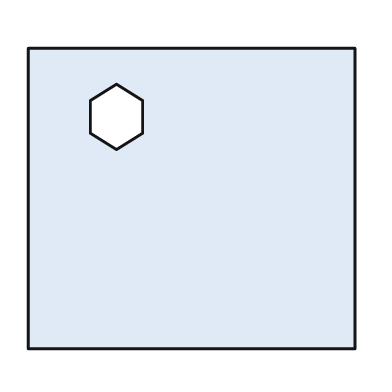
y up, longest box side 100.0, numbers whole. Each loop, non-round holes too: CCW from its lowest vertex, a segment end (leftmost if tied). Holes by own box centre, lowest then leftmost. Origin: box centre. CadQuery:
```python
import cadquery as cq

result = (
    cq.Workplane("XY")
    .moveTo(-50.0, -46.0)
    .lineTo(50.0, -46.0)
    .lineTo(50.0, 46.0)
    .lineTo(-50.0, 46.0)
    .close()
    .moveTo(-23.0, 15.0)
    .lineTo(-15.0, 20.0)
    .lineTo(-15.0, 30.0)
    .lineTo(-23.0, 35.0)
    .lineTo(-31.0, 30.0)
    .lineTo(-31.0, 20.0)
    .close()
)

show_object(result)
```